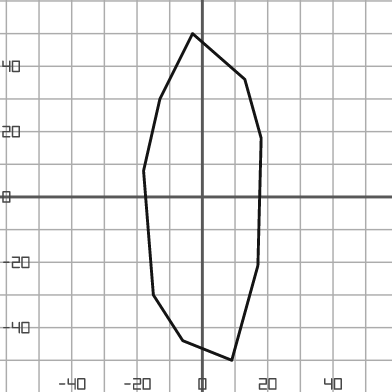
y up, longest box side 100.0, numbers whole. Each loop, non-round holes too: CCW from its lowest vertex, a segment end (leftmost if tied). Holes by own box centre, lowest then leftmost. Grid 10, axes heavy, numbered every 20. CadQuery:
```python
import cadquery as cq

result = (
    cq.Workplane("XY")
    .moveTo(9.0, -50.0)
    .lineTo(17.0, -21.0)
    .lineTo(18.0, 18.0)
    .lineTo(13.0, 36.0)
    .lineTo(-3.0, 50.0)
    .lineTo(-13.0, 30.0)
    .lineTo(-18.0, 8.0)
    .lineTo(-15.0, -30.0)
    .lineTo(-6.0, -44.0)
    .close()
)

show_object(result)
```